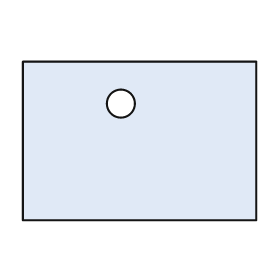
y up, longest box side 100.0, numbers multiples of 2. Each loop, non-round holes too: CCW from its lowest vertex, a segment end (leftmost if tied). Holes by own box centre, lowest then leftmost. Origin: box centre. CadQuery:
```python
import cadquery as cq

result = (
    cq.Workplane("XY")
    .moveTo(-50.0, -34.0)
    .lineTo(50.0, -34.0)
    .lineTo(50.0, 34.0)
    .lineTo(-50.0, 34.0)
    .close()
    .moveTo(-8.0, 16.0)
    .circle(6.0)
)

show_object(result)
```